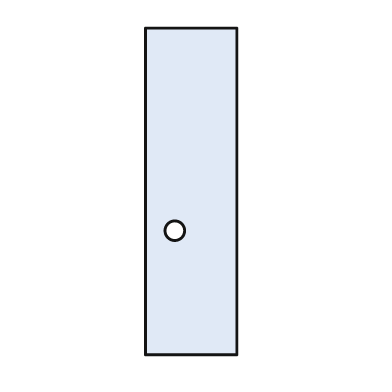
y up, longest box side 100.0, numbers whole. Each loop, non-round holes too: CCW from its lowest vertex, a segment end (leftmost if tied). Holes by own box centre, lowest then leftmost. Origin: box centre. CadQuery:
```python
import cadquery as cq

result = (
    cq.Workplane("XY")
    .moveTo(-14.0, -50.0)
    .lineTo(14.0, -50.0)
    .lineTo(14.0, 50.0)
    .lineTo(-14.0, 50.0)
    .close()
    .moveTo(-5.0, -12.0)
    .circle(3.0)
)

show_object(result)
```